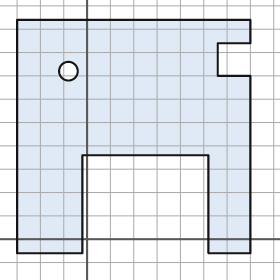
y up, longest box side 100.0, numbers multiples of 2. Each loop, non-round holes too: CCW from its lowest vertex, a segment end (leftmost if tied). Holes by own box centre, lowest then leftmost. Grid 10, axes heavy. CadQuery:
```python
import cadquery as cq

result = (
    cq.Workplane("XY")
    .moveTo(-30.0, -6.0)
    .lineTo(-2.0, -6.0)
    .lineTo(-2.0, 36.0)
    .lineTo(52.0, 36.0)
    .lineTo(52.0, -6.0)
    .lineTo(70.0, -6.0)
    .lineTo(70.0, 70.0)
    .lineTo(56.0, 70.0)
    .lineTo(56.0, 84.0)
    .lineTo(70.0, 84.0)
    .lineTo(70.0, 94.0)
    .lineTo(-30.0, 94.0)
    .close()
    .moveTo(-8.0, 72.0)
    .circle(4.0)
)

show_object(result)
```